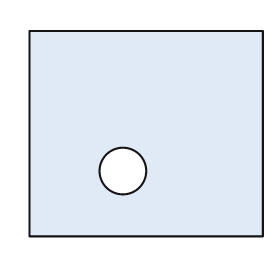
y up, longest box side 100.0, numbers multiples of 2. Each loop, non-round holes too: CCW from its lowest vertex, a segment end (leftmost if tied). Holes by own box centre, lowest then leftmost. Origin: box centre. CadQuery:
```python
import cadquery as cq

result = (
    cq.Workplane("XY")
    .moveTo(-50.0, -44.0)
    .lineTo(50.0, -44.0)
    .lineTo(50.0, 44.0)
    .lineTo(-50.0, 44.0)
    .close()
    .moveTo(-10.0, -16.0)
    .circle(10.0)
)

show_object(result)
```